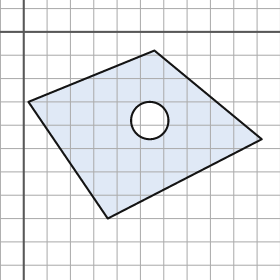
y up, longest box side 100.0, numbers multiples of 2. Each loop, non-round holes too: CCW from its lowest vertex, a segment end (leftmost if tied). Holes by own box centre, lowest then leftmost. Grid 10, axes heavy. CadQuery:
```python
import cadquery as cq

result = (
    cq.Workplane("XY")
    .moveTo(36.0, -80.0)
    .lineTo(102.0, -46.0)
    .lineTo(56.0, -8.0)
    .lineTo(2.0, -30.0)
    .close()
    .moveTo(54.0, -38.0)
    .circle(8.0)
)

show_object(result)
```